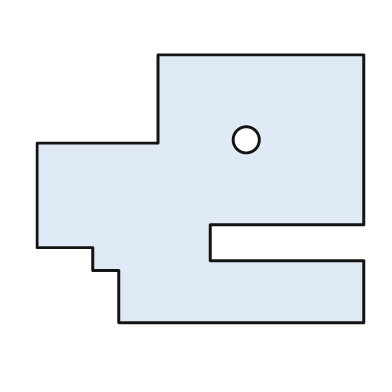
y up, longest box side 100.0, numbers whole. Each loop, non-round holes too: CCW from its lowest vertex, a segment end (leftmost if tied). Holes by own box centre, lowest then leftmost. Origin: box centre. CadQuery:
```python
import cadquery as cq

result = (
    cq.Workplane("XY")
    .moveTo(-25.0, -41.0)
    .lineTo(50.0, -41.0)
    .lineTo(50.0, -22.0)
    .lineTo(3.0, -22.0)
    .lineTo(3.0, -11.0)
    .lineTo(50.0, -11.0)
    .lineTo(50.0, 41.0)
    .lineTo(-13.0, 41.0)
    .lineTo(-13.0, 14.0)
    .lineTo(-50.0, 14.0)
    .lineTo(-50.0, -18.0)
    .lineTo(-33.0, -18.0)
    .lineTo(-33.0, -25.0)
    .lineTo(-25.0, -25.0)
    .close()
    .moveTo(14.0, 15.0)
    .circle(4.0)
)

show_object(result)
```